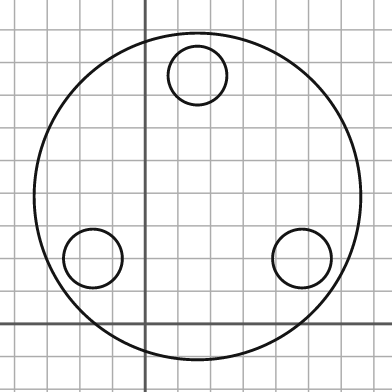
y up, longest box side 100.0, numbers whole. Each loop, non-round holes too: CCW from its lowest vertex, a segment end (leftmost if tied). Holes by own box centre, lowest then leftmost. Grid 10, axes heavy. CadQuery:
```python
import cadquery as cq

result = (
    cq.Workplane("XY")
    .moveTo(16.0, 39.0)
    .circle(50.0)
    .moveTo(-16.0, 20.0)
    .circle(9.0)
    .moveTo(48.0, 20.0)
    .circle(9.0)
    .moveTo(16.0, 76.0)
    .circle(9.0)
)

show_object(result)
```